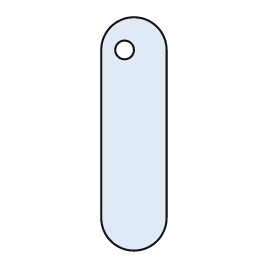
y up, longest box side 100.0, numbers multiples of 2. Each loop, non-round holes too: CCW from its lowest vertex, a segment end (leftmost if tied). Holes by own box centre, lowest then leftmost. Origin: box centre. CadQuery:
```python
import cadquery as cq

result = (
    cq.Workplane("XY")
    .moveTo(-14.0, -36.0)
    .threePointArc((0.0, -50.0), (14.0, -36.0))
    .lineTo(14.0, 36.0)
    .threePointArc((0.0, 50.0), (-14.0, 36.0))
    .close()
    .moveTo(-4.0, 36.0)
    .circle(4.0)
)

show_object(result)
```